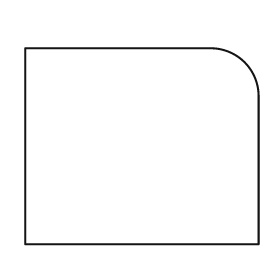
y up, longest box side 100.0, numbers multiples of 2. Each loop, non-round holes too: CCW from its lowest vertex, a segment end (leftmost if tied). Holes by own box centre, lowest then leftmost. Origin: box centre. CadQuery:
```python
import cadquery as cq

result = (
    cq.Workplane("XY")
    .moveTo(-50.0, -42.0)
    .lineTo(50.0, -42.0)
    .lineTo(50.0, 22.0)
    .threePointArc((44.0, 36.0), (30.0, 42.0))
    .lineTo(-50.0, 42.0)
    .close()
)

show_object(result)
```